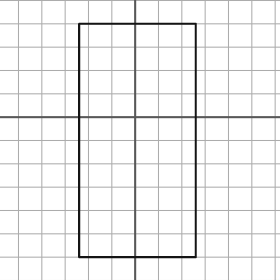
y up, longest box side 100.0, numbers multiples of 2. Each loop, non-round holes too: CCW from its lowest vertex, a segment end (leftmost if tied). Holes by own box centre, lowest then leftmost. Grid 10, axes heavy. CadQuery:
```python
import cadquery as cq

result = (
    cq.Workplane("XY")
    .moveTo(-24.0, -60.0)
    .lineTo(26.0, -60.0)
    .lineTo(26.0, 40.0)
    .lineTo(-24.0, 40.0)
    .close()
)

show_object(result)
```